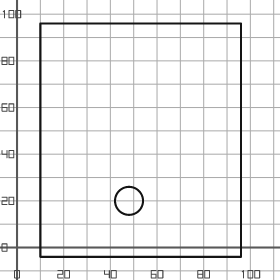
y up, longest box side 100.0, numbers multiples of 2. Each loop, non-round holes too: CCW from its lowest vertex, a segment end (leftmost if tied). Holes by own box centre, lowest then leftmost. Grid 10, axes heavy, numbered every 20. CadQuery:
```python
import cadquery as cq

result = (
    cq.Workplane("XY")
    .moveTo(10.0, -4.0)
    .lineTo(96.0, -4.0)
    .lineTo(96.0, 96.0)
    .lineTo(10.0, 96.0)
    .close()
    .moveTo(48.0, 20.0)
    .circle(6.0)
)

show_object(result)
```